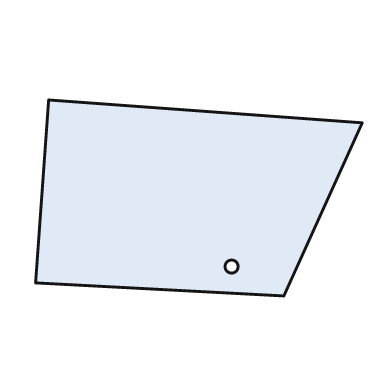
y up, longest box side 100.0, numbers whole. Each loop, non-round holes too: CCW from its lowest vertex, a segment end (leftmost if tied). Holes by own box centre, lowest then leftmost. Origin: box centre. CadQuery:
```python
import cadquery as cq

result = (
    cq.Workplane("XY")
    .moveTo(26.0, -30.0)
    .lineTo(50.0, 23.0)
    .lineTo(-46.0, 30.0)
    .lineTo(-50.0, -26.0)
    .close()
    .moveTo(10.0, -21.0)
    .circle(2.0)
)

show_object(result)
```